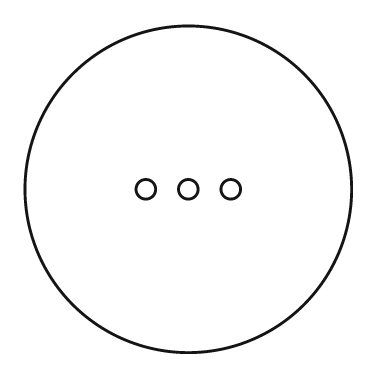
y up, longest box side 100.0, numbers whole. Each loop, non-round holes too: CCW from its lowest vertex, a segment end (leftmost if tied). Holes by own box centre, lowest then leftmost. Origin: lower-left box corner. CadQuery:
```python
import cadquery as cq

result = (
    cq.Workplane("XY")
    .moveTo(50.0, 50.0)
    .circle(50.0)
    .moveTo(37.0, 50.0)
    .circle(3.0)
    .moveTo(50.0, 50.0)
    .circle(3.0)
    .moveTo(63.0, 50.0)
    .circle(3.0)
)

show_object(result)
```